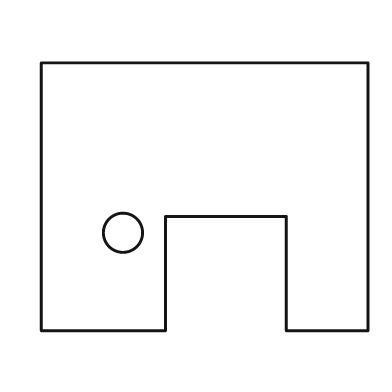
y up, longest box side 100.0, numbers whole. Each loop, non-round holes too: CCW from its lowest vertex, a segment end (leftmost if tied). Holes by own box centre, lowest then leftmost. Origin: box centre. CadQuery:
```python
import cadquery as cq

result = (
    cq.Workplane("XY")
    .moveTo(-50.0, -41.0)
    .lineTo(-12.0, -41.0)
    .lineTo(-12.0, -6.0)
    .lineTo(25.0, -6.0)
    .lineTo(25.0, -41.0)
    .lineTo(50.0, -41.0)
    .lineTo(50.0, 41.0)
    .lineTo(-50.0, 41.0)
    .close()
    .moveTo(-25.0, -11.0)
    .circle(6.0)
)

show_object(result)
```